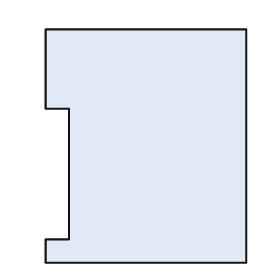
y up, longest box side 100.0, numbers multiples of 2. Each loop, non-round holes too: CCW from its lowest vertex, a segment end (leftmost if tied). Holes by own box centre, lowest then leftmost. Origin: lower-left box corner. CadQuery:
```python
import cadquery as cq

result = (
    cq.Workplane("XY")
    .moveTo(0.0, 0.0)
    .lineTo(86.0, 0.0)
    .lineTo(86.0, 100.0)
    .lineTo(0.0, 100.0)
    .lineTo(0.0, 66.0)
    .lineTo(10.0, 66.0)
    .lineTo(10.0, 10.0)
    .lineTo(0.0, 10.0)
    .close()
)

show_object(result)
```